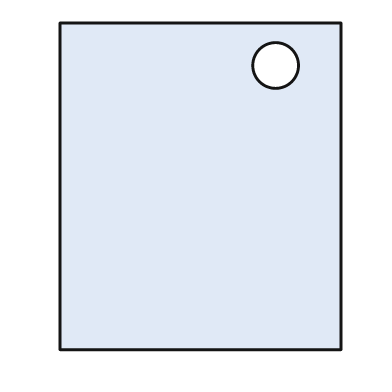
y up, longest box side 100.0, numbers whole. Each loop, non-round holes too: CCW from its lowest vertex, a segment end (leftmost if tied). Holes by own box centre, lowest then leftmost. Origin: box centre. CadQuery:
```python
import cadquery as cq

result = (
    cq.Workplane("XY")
    .moveTo(-43.0, -50.0)
    .lineTo(43.0, -50.0)
    .lineTo(43.0, 50.0)
    .lineTo(-43.0, 50.0)
    .close()
    .moveTo(23.0, 37.0)
    .circle(7.0)
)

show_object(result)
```